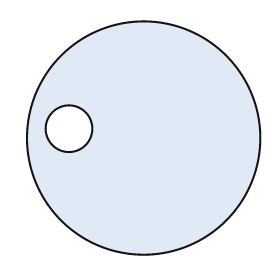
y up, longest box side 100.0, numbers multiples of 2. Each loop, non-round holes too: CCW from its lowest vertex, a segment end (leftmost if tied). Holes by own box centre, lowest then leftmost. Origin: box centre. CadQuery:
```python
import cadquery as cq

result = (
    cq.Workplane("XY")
    .moveTo(0.0, 0.0)
    .circle(50.0)
    .moveTo(-32.0, 4.0)
    .circle(10.0)
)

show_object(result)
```